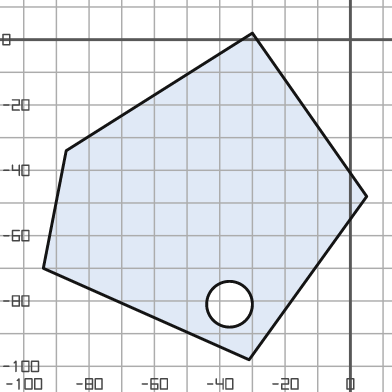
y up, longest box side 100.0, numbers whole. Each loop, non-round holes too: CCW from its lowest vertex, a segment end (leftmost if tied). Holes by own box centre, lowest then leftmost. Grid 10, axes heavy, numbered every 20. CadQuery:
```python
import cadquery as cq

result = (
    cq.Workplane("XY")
    .moveTo(-31.0, -98.0)
    .lineTo(5.0, -48.0)
    .lineTo(-30.0, 2.0)
    .lineTo(-87.0, -34.0)
    .lineTo(-94.0, -70.0)
    .close()
    .moveTo(-37.0, -81.0)
    .circle(7.0)
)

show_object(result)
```